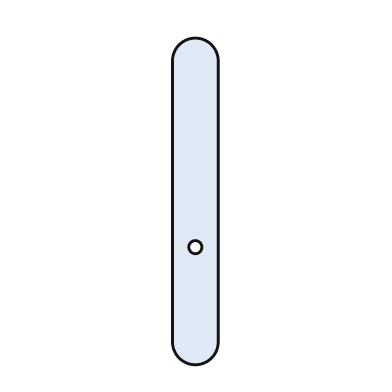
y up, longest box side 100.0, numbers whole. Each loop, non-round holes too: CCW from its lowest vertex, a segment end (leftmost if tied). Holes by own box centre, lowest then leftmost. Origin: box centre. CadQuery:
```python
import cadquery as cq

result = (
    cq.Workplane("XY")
    .moveTo(-7.0, -43.0)
    .threePointArc((0.0, -50.0), (7.0, -43.0))
    .lineTo(7.0, 43.0)
    .threePointArc((0.0, 50.0), (-7.0, 43.0))
    .close()
    .moveTo(0.0, -14.0)
    .circle(2.0)
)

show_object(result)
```